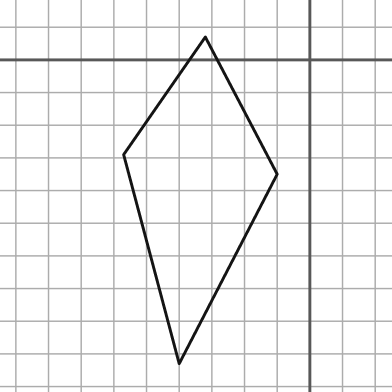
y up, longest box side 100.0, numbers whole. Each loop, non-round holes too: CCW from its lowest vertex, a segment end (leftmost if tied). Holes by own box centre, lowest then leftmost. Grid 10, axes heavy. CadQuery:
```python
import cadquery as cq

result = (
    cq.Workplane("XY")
    .moveTo(-40.0, -93.0)
    .lineTo(-10.0, -35.0)
    .lineTo(-32.0, 7.0)
    .lineTo(-57.0, -29.0)
    .close()
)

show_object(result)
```